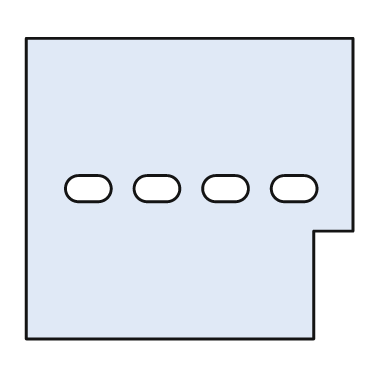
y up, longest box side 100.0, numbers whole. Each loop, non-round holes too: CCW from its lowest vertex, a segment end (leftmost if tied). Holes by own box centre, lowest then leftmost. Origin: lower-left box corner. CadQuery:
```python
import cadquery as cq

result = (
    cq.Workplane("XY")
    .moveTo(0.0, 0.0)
    .lineTo(88.0, 0.0)
    .lineTo(88.0, 33.0)
    .lineTo(100.0, 33.0)
    .lineTo(100.0, 92.0)
    .lineTo(0.0, 92.0)
    .close()
    .moveTo(16.0, 42.0)
    .lineTo(22.0, 42.0)
    .threePointArc((26.0, 46.0), (22.0, 50.0))
    .lineTo(16.0, 50.0)
    .threePointArc((12.0, 46.0), (16.0, 42.0))
    .close()
    .moveTo(37.0, 42.0)
    .lineTo(43.0, 42.0)
    .threePointArc((47.0, 46.0), (43.0, 50.0))
    .lineTo(37.0, 50.0)
    .threePointArc((33.0, 46.0), (37.0, 42.0))
    .close()
    .moveTo(58.0, 42.0)
    .lineTo(64.0, 42.0)
    .threePointArc((68.0, 46.0), (64.0, 50.0))
    .lineTo(58.0, 50.0)
    .threePointArc((54.0, 46.0), (58.0, 42.0))
    .close()
    .moveTo(79.0, 42.0)
    .lineTo(85.0, 42.0)
    .threePointArc((89.0, 46.0), (85.0, 50.0))
    .lineTo(79.0, 50.0)
    .threePointArc((75.0, 46.0), (79.0, 42.0))
    .close()
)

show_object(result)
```